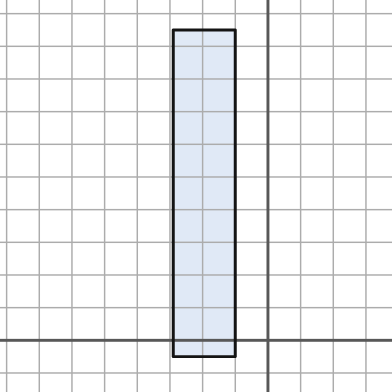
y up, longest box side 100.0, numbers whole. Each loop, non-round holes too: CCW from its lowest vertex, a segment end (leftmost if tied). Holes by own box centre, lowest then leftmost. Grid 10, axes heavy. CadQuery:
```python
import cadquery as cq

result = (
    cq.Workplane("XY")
    .moveTo(-29.0, -5.0)
    .lineTo(-10.0, -5.0)
    .lineTo(-10.0, 95.0)
    .lineTo(-29.0, 95.0)
    .close()
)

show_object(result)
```